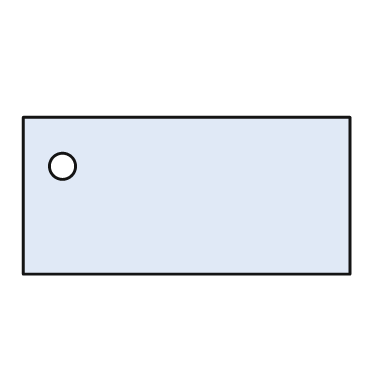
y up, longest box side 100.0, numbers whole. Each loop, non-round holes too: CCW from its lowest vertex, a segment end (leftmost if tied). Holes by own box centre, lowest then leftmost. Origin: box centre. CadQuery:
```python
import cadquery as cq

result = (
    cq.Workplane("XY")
    .moveTo(-50.0, -24.0)
    .lineTo(50.0, -24.0)
    .lineTo(50.0, 24.0)
    .lineTo(-50.0, 24.0)
    .close()
    .moveTo(-38.0, 9.0)
    .circle(4.0)
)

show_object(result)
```